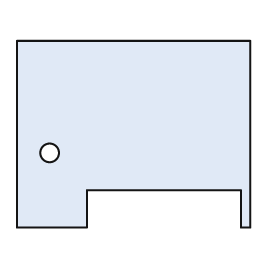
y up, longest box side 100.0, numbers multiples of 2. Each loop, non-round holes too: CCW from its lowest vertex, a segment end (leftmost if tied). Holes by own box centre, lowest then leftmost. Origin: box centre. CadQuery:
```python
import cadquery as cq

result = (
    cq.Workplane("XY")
    .moveTo(-50.0, -40.0)
    .lineTo(-20.0, -40.0)
    .lineTo(-20.0, -24.0)
    .lineTo(46.0, -24.0)
    .lineTo(46.0, -40.0)
    .lineTo(50.0, -40.0)
    .lineTo(50.0, 40.0)
    .lineTo(-50.0, 40.0)
    .close()
    .moveTo(-36.0, -8.0)
    .circle(4.0)
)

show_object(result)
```